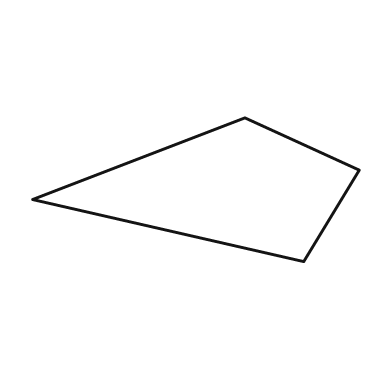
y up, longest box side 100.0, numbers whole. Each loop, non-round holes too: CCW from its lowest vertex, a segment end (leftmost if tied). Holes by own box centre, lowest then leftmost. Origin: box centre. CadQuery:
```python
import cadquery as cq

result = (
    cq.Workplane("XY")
    .moveTo(33.0, -22.0)
    .lineTo(50.0, 6.0)
    .lineTo(15.0, 22.0)
    .lineTo(-50.0, -3.0)
    .close()
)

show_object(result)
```